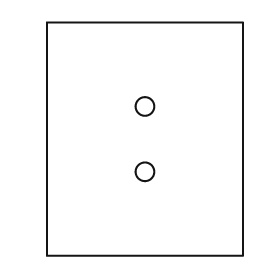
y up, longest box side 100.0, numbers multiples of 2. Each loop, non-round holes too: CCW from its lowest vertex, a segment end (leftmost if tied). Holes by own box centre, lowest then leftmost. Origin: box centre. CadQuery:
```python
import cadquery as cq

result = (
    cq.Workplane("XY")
    .moveTo(-42.0, -50.0)
    .lineTo(42.0, -50.0)
    .lineTo(42.0, 50.0)
    .lineTo(-42.0, 50.0)
    .close()
    .moveTo(0.0, -14.0)
    .circle(4.0)
    .moveTo(0.0, 14.0)
    .circle(4.0)
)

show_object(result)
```